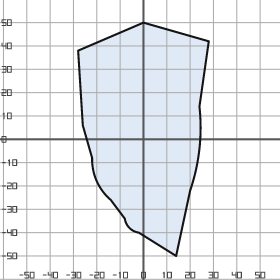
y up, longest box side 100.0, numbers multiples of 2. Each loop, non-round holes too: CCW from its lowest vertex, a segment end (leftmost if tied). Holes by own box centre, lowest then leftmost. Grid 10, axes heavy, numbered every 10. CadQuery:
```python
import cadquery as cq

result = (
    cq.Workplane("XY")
    .moveTo(14.0, -50.0)
    .lineTo(20.0, -22.0)
    .threePointArc((24.0, -4.0), (24.0, 14.0))
    .lineTo(28.0, 42.0)
    .lineTo(0.0, 50.0)
    .lineTo(-28.0, 38.0)
    .lineTo(-26.0, 6.0)
    .lineTo(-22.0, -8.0)
    .threePointArc((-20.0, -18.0), (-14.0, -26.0))
    .lineTo(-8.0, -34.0)
    .threePointArc((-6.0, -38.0), (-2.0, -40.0))
    .close()
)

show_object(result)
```